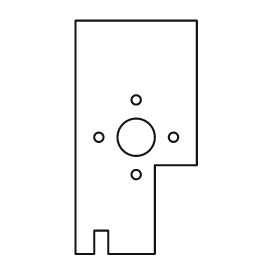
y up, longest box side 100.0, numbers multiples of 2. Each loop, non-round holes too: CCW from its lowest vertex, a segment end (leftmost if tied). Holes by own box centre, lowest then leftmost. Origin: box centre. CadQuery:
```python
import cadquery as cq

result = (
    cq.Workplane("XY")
    .moveTo(-26.0, -50.0)
    .lineTo(-18.0, -50.0)
    .lineTo(-18.0, -40.0)
    .lineTo(-12.0, -40.0)
    .lineTo(-12.0, -50.0)
    .lineTo(8.0, -50.0)
    .lineTo(8.0, -12.0)
    .lineTo(26.0, -12.0)
    .lineTo(26.0, 50.0)
    .lineTo(-26.0, 50.0)
    .close()
    .moveTo(0.0, -16.0)
    .circle(2.0)
    .moveTo(-16.0, 0.0)
    .circle(2.0)
    .moveTo(0.0, 0.0)
    .circle(8.0)
    .moveTo(16.0, 0.0)
    .circle(2.0)
    .moveTo(0.0, 16.0)
    .circle(2.0)
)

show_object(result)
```